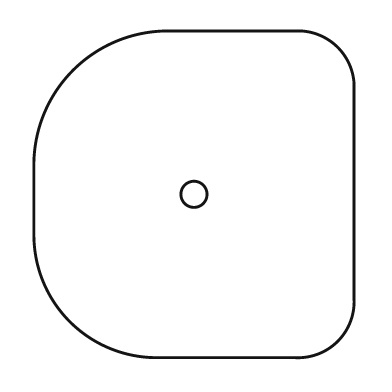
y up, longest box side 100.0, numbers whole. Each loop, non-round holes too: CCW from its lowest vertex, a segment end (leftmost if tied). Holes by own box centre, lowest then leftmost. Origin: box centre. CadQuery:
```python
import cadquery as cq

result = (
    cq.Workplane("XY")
    .moveTo(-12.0, -50.0)
    .lineTo(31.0, -50.0)
    .threePointArc((44.0, -45.0), (49.0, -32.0))
    .lineTo(49.0, 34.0)
    .threePointArc((44.0, 45.0), (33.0, 50.0))
    .lineTo(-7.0, 50.0)
    .threePointArc((-37.0, 38.0), (-49.0, 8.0))
    .lineTo(-49.0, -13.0)
    .threePointArc((-38.0, -39.0), (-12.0, -50.0))
    .close()
    .moveTo(0.0, 0.0)
    .circle(4.0)
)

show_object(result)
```